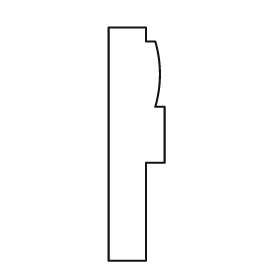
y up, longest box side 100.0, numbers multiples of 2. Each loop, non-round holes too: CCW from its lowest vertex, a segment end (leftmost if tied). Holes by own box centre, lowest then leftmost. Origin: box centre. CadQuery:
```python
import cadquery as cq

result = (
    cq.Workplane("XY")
    .moveTo(-12.0, -50.0)
    .lineTo(4.0, -50.0)
    .lineTo(4.0, -8.0)
    .lineTo(12.0, -8.0)
    .lineTo(12.0, 16.0)
    .lineTo(8.0, 16.0)
    .threePointArc((10.0, 30.0), (8.0, 44.0))
    .lineTo(4.0, 44.0)
    .lineTo(4.0, 50.0)
    .lineTo(-12.0, 50.0)
    .close()
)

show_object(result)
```